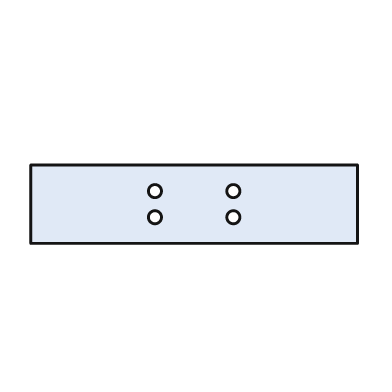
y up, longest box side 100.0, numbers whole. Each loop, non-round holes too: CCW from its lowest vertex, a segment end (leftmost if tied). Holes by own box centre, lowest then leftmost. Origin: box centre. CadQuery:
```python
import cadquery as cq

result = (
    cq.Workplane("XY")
    .moveTo(-50.0, -12.0)
    .lineTo(50.0, -12.0)
    .lineTo(50.0, 12.0)
    .lineTo(-50.0, 12.0)
    .close()
    .moveTo(-12.0, -4.0)
    .circle(2.0)
    .moveTo(12.0, -4.0)
    .circle(2.0)
    .moveTo(-12.0, 4.0)
    .circle(2.0)
    .moveTo(12.0, 4.0)
    .circle(2.0)
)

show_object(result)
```